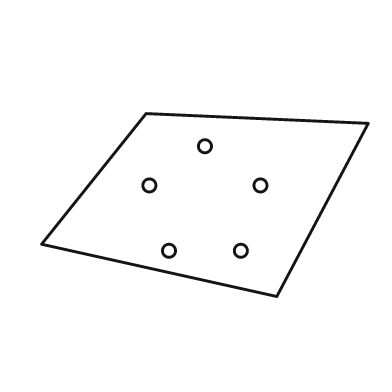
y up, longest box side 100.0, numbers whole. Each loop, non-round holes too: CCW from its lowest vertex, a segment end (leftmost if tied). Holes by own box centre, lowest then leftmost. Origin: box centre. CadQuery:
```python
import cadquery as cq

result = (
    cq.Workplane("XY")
    .moveTo(22.0, -28.0)
    .lineTo(50.0, 25.0)
    .lineTo(-18.0, 28.0)
    .lineTo(-50.0, -12.0)
    .close()
    .moveTo(-11.0, -14.0)
    .circle(2.0)
    .moveTo(11.0, -14.0)
    .circle(2.0)
    .moveTo(-17.0, 6.0)
    .circle(2.0)
    .moveTo(17.0, 6.0)
    .circle(2.0)
    .moveTo(0.0, 18.0)
    .circle(2.0)
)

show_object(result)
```